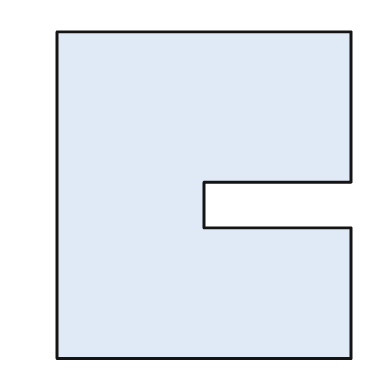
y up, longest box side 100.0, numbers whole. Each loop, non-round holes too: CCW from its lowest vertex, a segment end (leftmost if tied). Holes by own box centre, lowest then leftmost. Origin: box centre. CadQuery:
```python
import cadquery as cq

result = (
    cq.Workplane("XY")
    .moveTo(-45.0, -50.0)
    .lineTo(45.0, -50.0)
    .lineTo(45.0, -10.0)
    .lineTo(0.0, -10.0)
    .lineTo(0.0, 4.0)
    .lineTo(45.0, 4.0)
    .lineTo(45.0, 50.0)
    .lineTo(-45.0, 50.0)
    .close()
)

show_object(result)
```